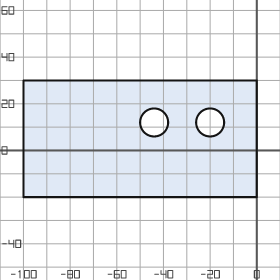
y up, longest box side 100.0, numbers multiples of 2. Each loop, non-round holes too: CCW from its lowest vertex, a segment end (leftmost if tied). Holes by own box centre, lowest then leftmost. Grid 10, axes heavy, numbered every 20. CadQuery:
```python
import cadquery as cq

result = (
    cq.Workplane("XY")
    .moveTo(-100.0, -20.0)
    .lineTo(0.0, -20.0)
    .lineTo(0.0, 30.0)
    .lineTo(-100.0, 30.0)
    .close()
    .moveTo(-44.0, 12.0)
    .circle(6.0)
    .moveTo(-20.0, 12.0)
    .circle(6.0)
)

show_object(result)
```